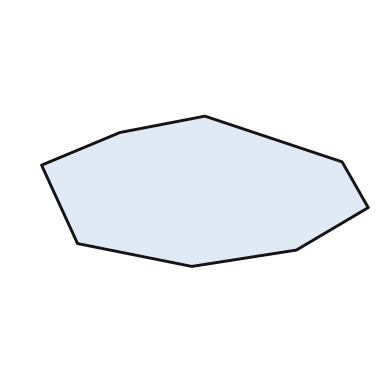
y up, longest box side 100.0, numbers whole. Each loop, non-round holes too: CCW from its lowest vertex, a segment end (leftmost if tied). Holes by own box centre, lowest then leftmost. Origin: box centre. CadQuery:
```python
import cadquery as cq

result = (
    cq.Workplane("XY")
    .moveTo(-4.0, -23.0)
    .lineTo(28.0, -18.0)
    .lineTo(50.0, -5.0)
    .lineTo(42.0, 9.0)
    .lineTo(0.0, 23.0)
    .lineTo(-26.0, 18.0)
    .lineTo(-50.0, 8.0)
    .lineTo(-39.0, -16.0)
    .close()
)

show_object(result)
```